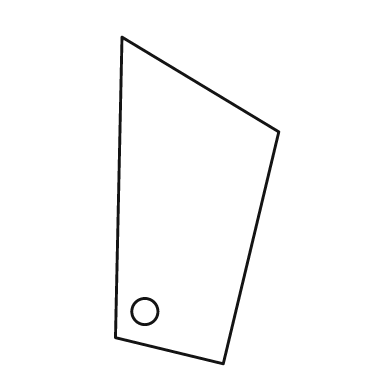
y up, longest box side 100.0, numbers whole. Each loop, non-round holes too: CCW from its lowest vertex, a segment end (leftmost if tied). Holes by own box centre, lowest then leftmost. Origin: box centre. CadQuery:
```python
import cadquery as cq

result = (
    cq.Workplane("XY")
    .moveTo(8.0, -50.0)
    .lineTo(25.0, 21.0)
    .lineTo(-23.0, 50.0)
    .lineTo(-25.0, -42.0)
    .close()
    .moveTo(-16.0, -34.0)
    .circle(4.0)
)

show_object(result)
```